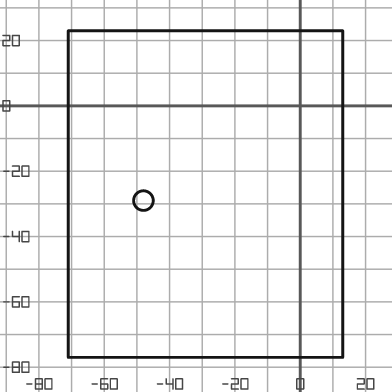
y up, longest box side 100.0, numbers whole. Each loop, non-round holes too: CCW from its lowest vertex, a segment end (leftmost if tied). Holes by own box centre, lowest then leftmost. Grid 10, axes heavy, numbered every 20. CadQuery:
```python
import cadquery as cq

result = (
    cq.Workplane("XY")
    .moveTo(-71.0, -77.0)
    .lineTo(13.0, -77.0)
    .lineTo(13.0, 23.0)
    .lineTo(-71.0, 23.0)
    .close()
    .moveTo(-48.0, -29.0)
    .circle(3.0)
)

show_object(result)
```